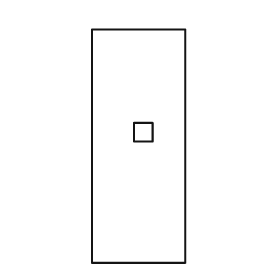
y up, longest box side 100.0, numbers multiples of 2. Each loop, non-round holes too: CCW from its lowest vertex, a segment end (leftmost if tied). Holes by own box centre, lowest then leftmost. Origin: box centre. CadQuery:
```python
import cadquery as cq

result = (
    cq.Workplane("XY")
    .moveTo(-20.0, -50.0)
    .lineTo(20.0, -50.0)
    .lineTo(20.0, 50.0)
    .lineTo(-20.0, 50.0)
    .close()
    .moveTo(-2.0, 2.0)
    .lineTo(6.0, 2.0)
    .lineTo(6.0, 10.0)
    .lineTo(-2.0, 10.0)
    .close()
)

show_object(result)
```